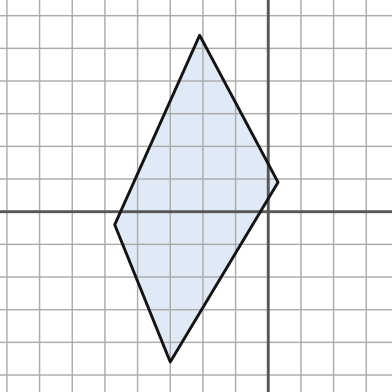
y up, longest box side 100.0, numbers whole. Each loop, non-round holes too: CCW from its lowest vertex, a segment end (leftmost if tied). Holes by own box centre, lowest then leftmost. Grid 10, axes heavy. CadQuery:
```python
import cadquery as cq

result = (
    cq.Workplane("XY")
    .moveTo(-30.0, -46.0)
    .lineTo(3.0, 9.0)
    .lineTo(-21.0, 54.0)
    .lineTo(-47.0, -4.0)
    .close()
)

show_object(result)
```